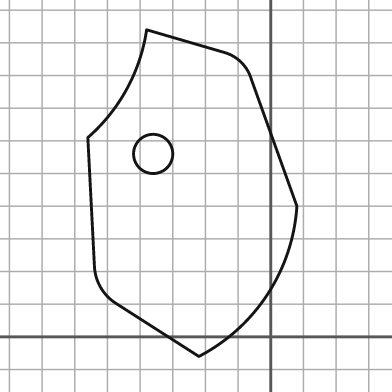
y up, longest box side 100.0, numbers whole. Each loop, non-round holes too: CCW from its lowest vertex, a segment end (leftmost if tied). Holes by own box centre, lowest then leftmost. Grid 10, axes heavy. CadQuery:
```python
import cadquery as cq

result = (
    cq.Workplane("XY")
    .moveTo(-22.0, -6.0)
    .threePointArc((-1.0, 13.0), (8.0, 40.0))
    .lineTo(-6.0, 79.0)
    .threePointArc((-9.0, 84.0), (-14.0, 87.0))
    .lineTo(-38.0, 94.0)
    .threePointArc((-44.0, 76.0), (-56.0, 61.0))
    .lineTo(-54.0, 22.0)
    .threePointArc((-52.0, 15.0), (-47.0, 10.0))
    .close()
    .moveTo(-36.0, 56.0)
    .circle(6.0)
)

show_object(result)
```